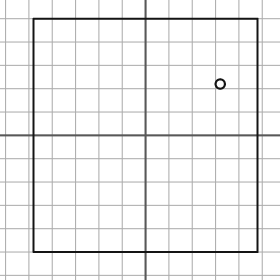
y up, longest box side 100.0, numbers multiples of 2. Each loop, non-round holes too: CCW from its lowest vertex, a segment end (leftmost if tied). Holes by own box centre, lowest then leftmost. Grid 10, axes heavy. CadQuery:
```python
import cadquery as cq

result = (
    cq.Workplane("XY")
    .moveTo(-48.0, -50.0)
    .lineTo(48.0, -50.0)
    .lineTo(48.0, 50.0)
    .lineTo(-48.0, 50.0)
    .close()
    .moveTo(32.0, 22.0)
    .circle(2.0)
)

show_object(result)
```